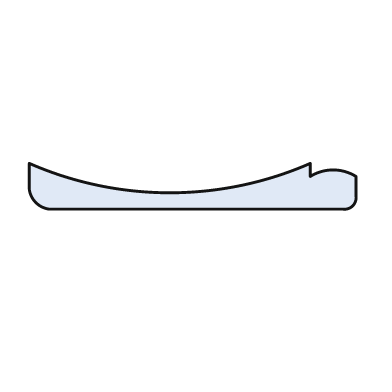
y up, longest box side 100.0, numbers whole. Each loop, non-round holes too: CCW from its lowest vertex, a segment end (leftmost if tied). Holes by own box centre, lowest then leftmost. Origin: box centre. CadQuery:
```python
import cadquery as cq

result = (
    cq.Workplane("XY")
    .moveTo(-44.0, -7.0)
    .lineTo(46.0, -7.0)
    .threePointArc((49.0, -6.0), (50.0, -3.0))
    .lineTo(50.0, 3.0)
    .threePointArc((43.0, 5.0), (36.0, 3.0))
    .lineTo(36.0, 7.0)
    .threePointArc((-7.0, -2.0), (-50.0, 7.0))
    .lineTo(-50.0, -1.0)
    .threePointArc((-48.0, -5.0), (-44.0, -7.0))
    .close()
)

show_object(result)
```